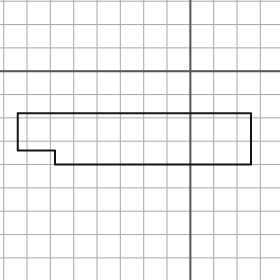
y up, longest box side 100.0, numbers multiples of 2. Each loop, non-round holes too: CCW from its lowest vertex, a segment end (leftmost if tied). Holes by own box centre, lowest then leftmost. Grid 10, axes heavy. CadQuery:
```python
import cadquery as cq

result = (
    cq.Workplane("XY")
    .moveTo(-58.0, -40.0)
    .lineTo(26.0, -40.0)
    .lineTo(26.0, -18.0)
    .lineTo(-74.0, -18.0)
    .lineTo(-74.0, -34.0)
    .lineTo(-58.0, -34.0)
    .close()
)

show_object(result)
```